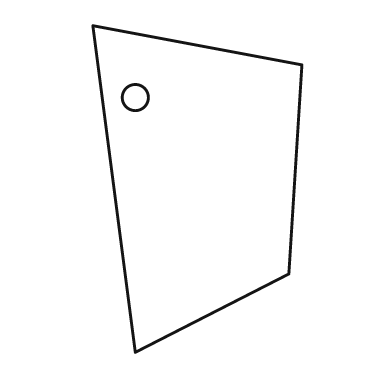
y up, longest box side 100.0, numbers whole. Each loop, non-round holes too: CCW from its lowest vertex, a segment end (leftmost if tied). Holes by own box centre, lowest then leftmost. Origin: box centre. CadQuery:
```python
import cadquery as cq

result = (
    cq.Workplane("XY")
    .moveTo(-19.0, -50.0)
    .lineTo(28.0, -26.0)
    .lineTo(32.0, 38.0)
    .lineTo(-32.0, 50.0)
    .close()
    .moveTo(-19.0, 28.0)
    .circle(4.0)
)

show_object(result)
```